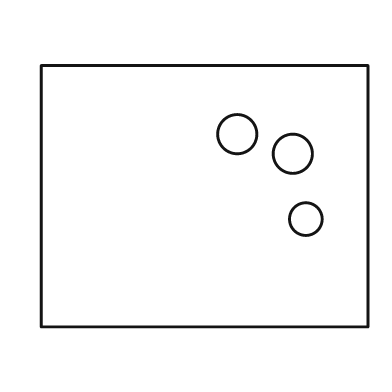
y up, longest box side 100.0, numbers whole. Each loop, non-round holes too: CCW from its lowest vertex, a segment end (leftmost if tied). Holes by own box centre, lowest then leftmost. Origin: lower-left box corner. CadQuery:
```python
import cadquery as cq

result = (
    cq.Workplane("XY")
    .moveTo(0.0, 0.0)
    .lineTo(100.0, 0.0)
    .lineTo(100.0, 80.0)
    .lineTo(0.0, 80.0)
    .close()
    .moveTo(81.0, 33.0)
    .circle(5.0)
    .moveTo(77.0, 53.0)
    .circle(6.0)
    .moveTo(60.0, 59.0)
    .circle(6.0)
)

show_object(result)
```